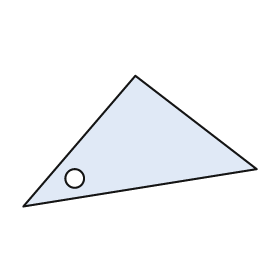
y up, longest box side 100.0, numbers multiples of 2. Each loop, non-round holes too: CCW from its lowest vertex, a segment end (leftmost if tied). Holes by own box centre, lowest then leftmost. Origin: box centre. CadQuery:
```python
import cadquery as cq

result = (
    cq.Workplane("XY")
    .moveTo(-50.0, -28.0)
    .lineTo(50.0, -12.0)
    .lineTo(-2.0, 28.0)
    .close()
    .moveTo(-28.0, -16.0)
    .circle(4.0)
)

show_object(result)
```